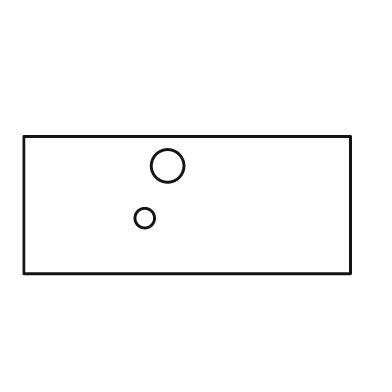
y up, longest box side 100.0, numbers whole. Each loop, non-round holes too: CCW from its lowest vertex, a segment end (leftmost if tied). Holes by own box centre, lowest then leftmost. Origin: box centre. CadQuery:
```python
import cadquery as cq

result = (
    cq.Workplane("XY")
    .moveTo(-50.0, -21.0)
    .lineTo(50.0, -21.0)
    .lineTo(50.0, 21.0)
    .lineTo(-50.0, 21.0)
    .close()
    .moveTo(-13.0, -4.0)
    .circle(3.0)
    .moveTo(-6.0, 12.0)
    .circle(5.0)
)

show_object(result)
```